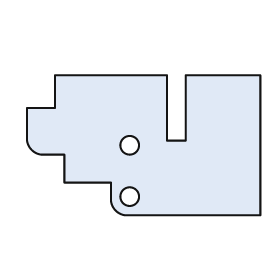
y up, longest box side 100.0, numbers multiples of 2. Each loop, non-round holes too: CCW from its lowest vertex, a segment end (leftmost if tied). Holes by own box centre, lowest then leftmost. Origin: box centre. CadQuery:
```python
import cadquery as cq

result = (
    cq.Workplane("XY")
    .moveTo(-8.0, -30.0)
    .lineTo(50.0, -30.0)
    .lineTo(50.0, 30.0)
    .lineTo(18.0, 30.0)
    .lineTo(18.0, 2.0)
    .lineTo(10.0, 2.0)
    .lineTo(10.0, 30.0)
    .lineTo(-38.0, 30.0)
    .lineTo(-38.0, 16.0)
    .lineTo(-50.0, 16.0)
    .lineTo(-50.0, 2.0)
    .threePointArc((-48.0, -2.0), (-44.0, -4.0))
    .lineTo(-34.0, -4.0)
    .lineTo(-34.0, -16.0)
    .lineTo(-14.0, -16.0)
    .lineTo(-14.0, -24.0)
    .threePointArc((-12.0, -28.0), (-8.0, -30.0))
    .close()
    .moveTo(-6.0, -22.0)
    .circle(4.0)
    .moveTo(-6.0, 0.0)
    .circle(4.0)
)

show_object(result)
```